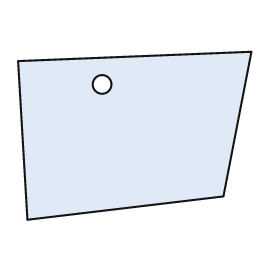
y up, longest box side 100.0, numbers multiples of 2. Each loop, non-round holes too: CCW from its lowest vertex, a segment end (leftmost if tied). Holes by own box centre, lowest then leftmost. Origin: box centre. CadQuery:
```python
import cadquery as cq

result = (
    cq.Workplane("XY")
    .moveTo(-46.0, -36.0)
    .lineTo(38.0, -26.0)
    .lineTo(50.0, 36.0)
    .lineTo(-50.0, 32.0)
    .close()
    .moveTo(-14.0, 22.0)
    .circle(4.0)
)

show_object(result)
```